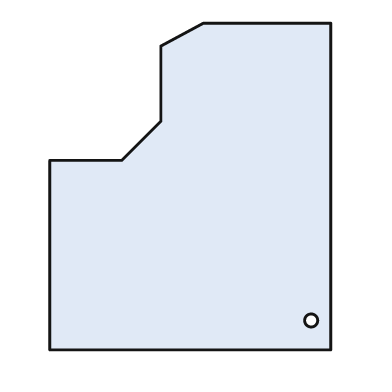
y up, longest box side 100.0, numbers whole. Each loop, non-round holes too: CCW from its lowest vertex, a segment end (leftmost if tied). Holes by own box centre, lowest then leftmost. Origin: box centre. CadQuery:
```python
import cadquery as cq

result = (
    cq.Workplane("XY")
    .moveTo(-43.0, -50.0)
    .lineTo(43.0, -50.0)
    .lineTo(43.0, 50.0)
    .lineTo(4.0, 50.0)
    .lineTo(-9.0, 43.0)
    .lineTo(-9.0, 20.0)
    .lineTo(-21.0, 8.0)
    .lineTo(-43.0, 8.0)
    .close()
    .moveTo(37.0, -41.0)
    .circle(2.0)
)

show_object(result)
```